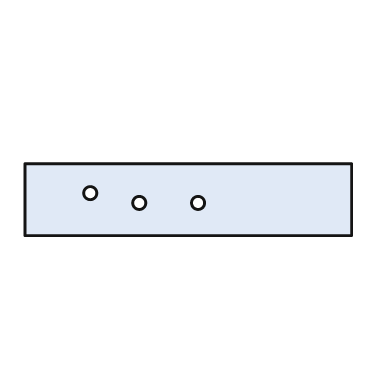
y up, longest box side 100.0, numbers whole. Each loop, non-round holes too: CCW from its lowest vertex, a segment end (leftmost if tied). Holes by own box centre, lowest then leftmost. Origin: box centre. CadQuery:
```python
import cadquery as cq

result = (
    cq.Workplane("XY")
    .moveTo(-50.0, -11.0)
    .lineTo(50.0, -11.0)
    .lineTo(50.0, 11.0)
    .lineTo(-50.0, 11.0)
    .close()
    .moveTo(-15.0, -1.0)
    .circle(2.0)
    .moveTo(3.0, -1.0)
    .circle(2.0)
    .moveTo(-30.0, 2.0)
    .circle(2.0)
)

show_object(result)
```